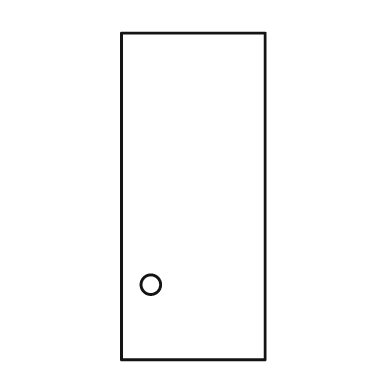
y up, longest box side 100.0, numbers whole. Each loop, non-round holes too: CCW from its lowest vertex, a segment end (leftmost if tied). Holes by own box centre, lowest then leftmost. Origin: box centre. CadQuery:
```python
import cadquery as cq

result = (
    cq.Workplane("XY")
    .moveTo(-22.0, -50.0)
    .lineTo(22.0, -50.0)
    .lineTo(22.0, 50.0)
    .lineTo(-22.0, 50.0)
    .close()
    .moveTo(-13.0, -27.0)
    .circle(3.0)
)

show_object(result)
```